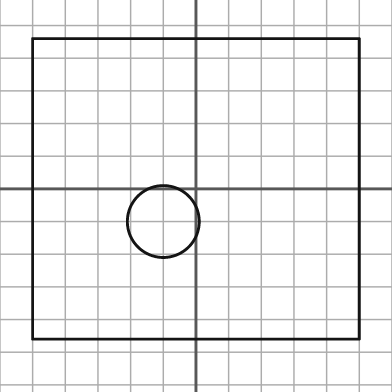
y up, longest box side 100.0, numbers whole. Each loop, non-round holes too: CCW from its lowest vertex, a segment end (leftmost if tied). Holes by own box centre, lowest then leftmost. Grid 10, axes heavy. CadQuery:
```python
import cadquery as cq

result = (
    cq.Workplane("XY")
    .moveTo(-50.0, -46.0)
    .lineTo(50.0, -46.0)
    .lineTo(50.0, 46.0)
    .lineTo(-50.0, 46.0)
    .close()
    .moveTo(-10.0, -10.0)
    .circle(11.0)
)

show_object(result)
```